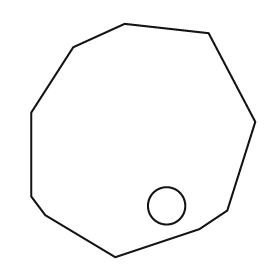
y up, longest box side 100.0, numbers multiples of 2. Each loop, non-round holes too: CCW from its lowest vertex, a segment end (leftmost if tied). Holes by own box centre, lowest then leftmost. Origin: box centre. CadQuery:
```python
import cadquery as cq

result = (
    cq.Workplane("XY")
    .moveTo(-12.0, -50.0)
    .lineTo(24.0, -38.0)
    .lineTo(36.0, -30.0)
    .lineTo(48.0, 8.0)
    .lineTo(28.0, 46.0)
    .lineTo(-8.0, 50.0)
    .lineTo(-30.0, 40.0)
    .lineTo(-48.0, 12.0)
    .lineTo(-48.0, -24.0)
    .lineTo(-42.0, -32.0)
    .close()
    .moveTo(10.0, -28.0)
    .circle(8.0)
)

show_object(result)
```